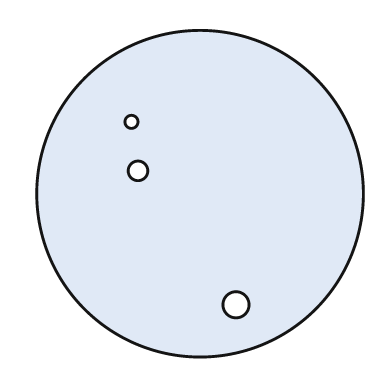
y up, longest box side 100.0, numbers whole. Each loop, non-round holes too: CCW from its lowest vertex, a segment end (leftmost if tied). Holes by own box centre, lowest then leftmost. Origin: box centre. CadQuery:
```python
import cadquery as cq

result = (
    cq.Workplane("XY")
    .moveTo(0.0, 0.0)
    .circle(50.0)
    .moveTo(11.0, -34.0)
    .circle(4.0)
    .moveTo(-19.0, 7.0)
    .circle(3.0)
    .moveTo(-21.0, 22.0)
    .circle(2.0)
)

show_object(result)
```